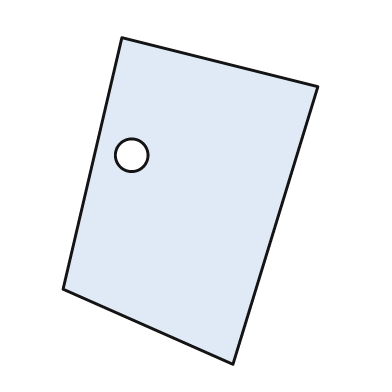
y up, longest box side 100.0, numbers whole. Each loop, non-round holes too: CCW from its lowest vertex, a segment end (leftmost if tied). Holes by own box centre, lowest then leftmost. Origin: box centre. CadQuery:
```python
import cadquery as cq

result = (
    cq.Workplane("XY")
    .moveTo(13.0, -50.0)
    .lineTo(39.0, 35.0)
    .lineTo(-21.0, 50.0)
    .lineTo(-39.0, -27.0)
    .close()
    .moveTo(-18.0, 14.0)
    .circle(5.0)
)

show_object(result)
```